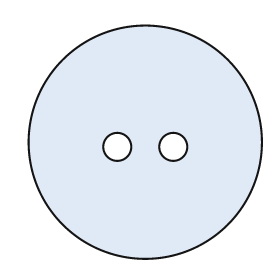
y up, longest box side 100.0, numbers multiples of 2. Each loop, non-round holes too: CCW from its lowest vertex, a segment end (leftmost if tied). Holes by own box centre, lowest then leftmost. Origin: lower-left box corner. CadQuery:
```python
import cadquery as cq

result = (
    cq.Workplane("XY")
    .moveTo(50.0, 50.0)
    .circle(50.0)
    .moveTo(38.0, 48.0)
    .circle(6.0)
    .moveTo(62.0, 48.0)
    .circle(6.0)
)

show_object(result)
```